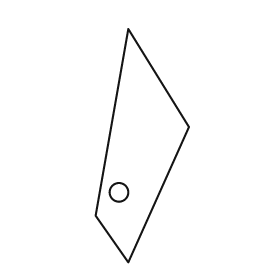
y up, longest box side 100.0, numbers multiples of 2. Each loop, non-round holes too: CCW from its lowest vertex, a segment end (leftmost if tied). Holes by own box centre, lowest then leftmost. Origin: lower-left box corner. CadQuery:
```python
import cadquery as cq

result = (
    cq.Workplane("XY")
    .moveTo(14.0, 0.0)
    .lineTo(40.0, 58.0)
    .lineTo(14.0, 100.0)
    .lineTo(0.0, 20.0)
    .close()
    .moveTo(10.0, 30.0)
    .circle(4.0)
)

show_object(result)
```